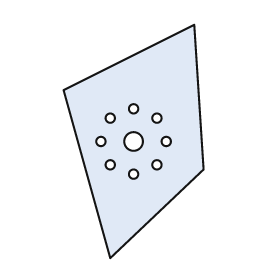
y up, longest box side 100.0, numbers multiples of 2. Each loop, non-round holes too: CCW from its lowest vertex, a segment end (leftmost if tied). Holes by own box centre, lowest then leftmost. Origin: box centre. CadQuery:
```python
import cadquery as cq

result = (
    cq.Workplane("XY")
    .moveTo(-10.0, -50.0)
    .lineTo(30.0, -12.0)
    .lineTo(26.0, 50.0)
    .lineTo(-30.0, 22.0)
    .close()
    .moveTo(0.0, -14.0)
    .circle(2.0)
    .moveTo(-10.0, -10.0)
    .circle(2.0)
    .moveTo(10.0, -10.0)
    .circle(2.0)
    .moveTo(-14.0, 0.0)
    .circle(2.0)
    .moveTo(0.0, 0.0)
    .circle(4.0)
    .moveTo(14.0, 0.0)
    .circle(2.0)
    .moveTo(-10.0, 10.0)
    .circle(2.0)
    .moveTo(10.0, 10.0)
    .circle(2.0)
    .moveTo(0.0, 14.0)
    .circle(2.0)
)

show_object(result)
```